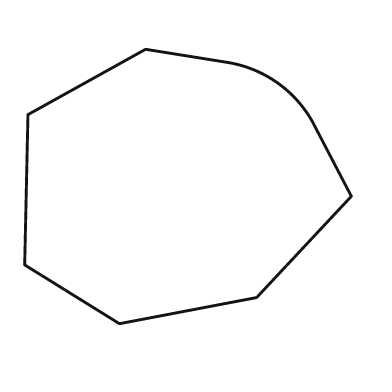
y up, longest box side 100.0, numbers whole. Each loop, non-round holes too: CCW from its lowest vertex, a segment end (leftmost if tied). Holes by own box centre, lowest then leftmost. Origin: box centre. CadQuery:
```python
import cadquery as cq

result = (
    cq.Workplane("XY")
    .moveTo(-21.0, -42.0)
    .lineTo(21.0, -34.0)
    .lineTo(50.0, -3.0)
    .lineTo(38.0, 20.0)
    .threePointArc((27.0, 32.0), (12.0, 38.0))
    .lineTo(-13.0, 42.0)
    .lineTo(-49.0, 22.0)
    .lineTo(-50.0, -24.0)
    .close()
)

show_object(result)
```